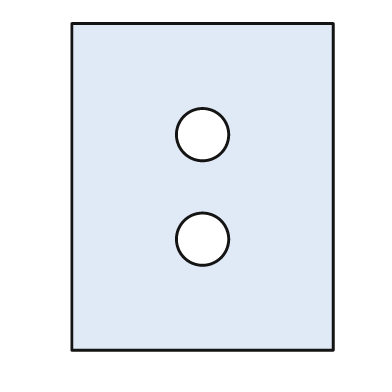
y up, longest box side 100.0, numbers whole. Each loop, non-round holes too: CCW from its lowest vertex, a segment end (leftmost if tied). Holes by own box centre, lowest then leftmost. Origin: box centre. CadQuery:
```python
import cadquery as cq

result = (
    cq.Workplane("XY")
    .moveTo(-40.0, -50.0)
    .lineTo(40.0, -50.0)
    .lineTo(40.0, 50.0)
    .lineTo(-40.0, 50.0)
    .close()
    .moveTo(0.0, -16.0)
    .circle(8.0)
    .moveTo(0.0, 16.0)
    .circle(8.0)
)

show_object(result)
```